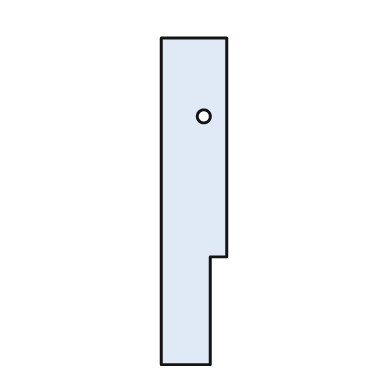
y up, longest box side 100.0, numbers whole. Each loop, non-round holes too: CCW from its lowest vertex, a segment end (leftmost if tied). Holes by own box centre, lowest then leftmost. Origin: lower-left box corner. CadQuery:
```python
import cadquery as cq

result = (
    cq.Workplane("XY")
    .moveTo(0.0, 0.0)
    .lineTo(15.0, 0.0)
    .lineTo(15.0, 33.0)
    .lineTo(20.0, 33.0)
    .lineTo(20.0, 100.0)
    .lineTo(0.0, 100.0)
    .close()
    .moveTo(13.0, 76.0)
    .circle(2.0)
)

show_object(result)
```